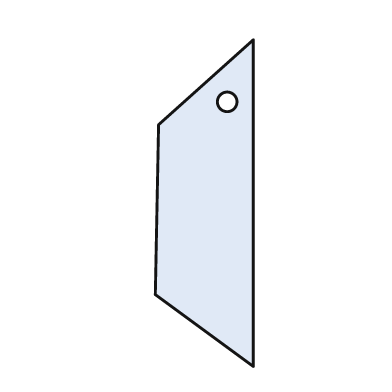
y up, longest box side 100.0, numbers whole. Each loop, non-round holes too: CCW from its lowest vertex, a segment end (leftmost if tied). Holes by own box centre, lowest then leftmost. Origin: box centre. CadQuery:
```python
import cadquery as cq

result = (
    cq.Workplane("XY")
    .moveTo(15.0, -50.0)
    .lineTo(15.0, 50.0)
    .lineTo(-14.0, 24.0)
    .lineTo(-15.0, -28.0)
    .close()
    .moveTo(7.0, 31.0)
    .circle(3.0)
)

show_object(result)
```